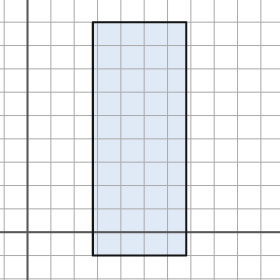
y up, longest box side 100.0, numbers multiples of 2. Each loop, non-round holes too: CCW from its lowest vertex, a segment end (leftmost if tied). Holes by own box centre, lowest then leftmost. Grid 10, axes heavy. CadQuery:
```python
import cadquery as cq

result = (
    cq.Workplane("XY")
    .moveTo(28.0, -10.0)
    .lineTo(68.0, -10.0)
    .lineTo(68.0, 90.0)
    .lineTo(28.0, 90.0)
    .close()
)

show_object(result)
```